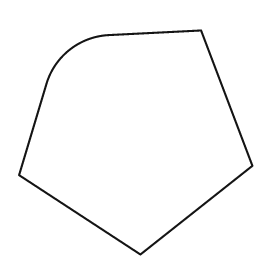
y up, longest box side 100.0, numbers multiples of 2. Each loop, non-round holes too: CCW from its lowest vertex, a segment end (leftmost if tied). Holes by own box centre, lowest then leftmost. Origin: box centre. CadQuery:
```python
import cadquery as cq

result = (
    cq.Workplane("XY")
    .moveTo(2.0, -48.0)
    .lineTo(50.0, -10.0)
    .lineTo(28.0, 48.0)
    .lineTo(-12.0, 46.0)
    .threePointArc((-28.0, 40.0), (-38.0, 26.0))
    .lineTo(-50.0, -14.0)
    .close()
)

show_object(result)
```